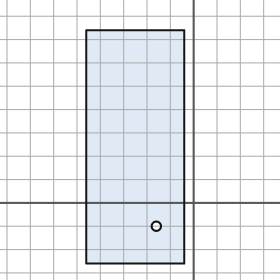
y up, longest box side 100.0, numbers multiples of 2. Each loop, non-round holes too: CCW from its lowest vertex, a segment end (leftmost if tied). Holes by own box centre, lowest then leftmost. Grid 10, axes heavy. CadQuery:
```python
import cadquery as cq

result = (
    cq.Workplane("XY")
    .moveTo(-46.0, -26.0)
    .lineTo(-4.0, -26.0)
    .lineTo(-4.0, 74.0)
    .lineTo(-46.0, 74.0)
    .close()
    .moveTo(-16.0, -10.0)
    .circle(2.0)
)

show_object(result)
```